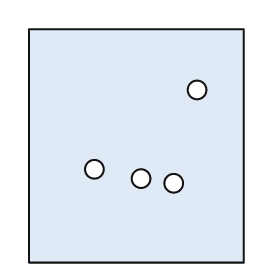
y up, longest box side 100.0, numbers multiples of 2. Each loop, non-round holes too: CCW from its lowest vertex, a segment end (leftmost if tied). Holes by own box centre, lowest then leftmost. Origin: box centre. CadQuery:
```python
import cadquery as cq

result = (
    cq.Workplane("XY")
    .moveTo(-46.0, -50.0)
    .lineTo(46.0, -50.0)
    .lineTo(46.0, 50.0)
    .lineTo(-46.0, 50.0)
    .close()
    .moveTo(16.0, -16.0)
    .circle(4.0)
    .moveTo(2.0, -14.0)
    .circle(4.0)
    .moveTo(-18.0, -10.0)
    .circle(4.0)
    .moveTo(26.0, 24.0)
    .circle(4.0)
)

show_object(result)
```